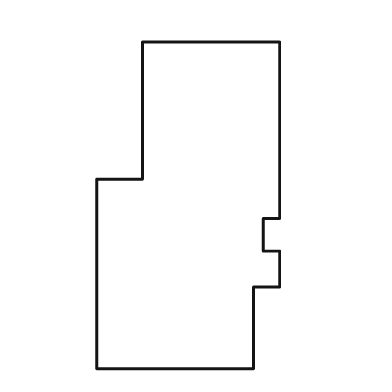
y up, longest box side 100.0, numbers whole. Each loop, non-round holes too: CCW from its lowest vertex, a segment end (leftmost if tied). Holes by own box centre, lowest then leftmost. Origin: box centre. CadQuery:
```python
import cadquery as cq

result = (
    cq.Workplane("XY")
    .moveTo(-28.0, -50.0)
    .lineTo(20.0, -50.0)
    .lineTo(20.0, -25.0)
    .lineTo(28.0, -25.0)
    .lineTo(28.0, -14.0)
    .lineTo(23.0, -14.0)
    .lineTo(23.0, -4.0)
    .lineTo(28.0, -4.0)
    .lineTo(28.0, 50.0)
    .lineTo(-14.0, 50.0)
    .lineTo(-14.0, 8.0)
    .lineTo(-28.0, 8.0)
    .close()
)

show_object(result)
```